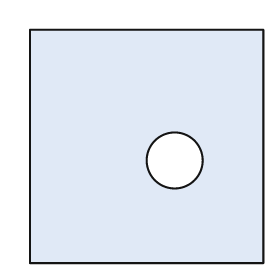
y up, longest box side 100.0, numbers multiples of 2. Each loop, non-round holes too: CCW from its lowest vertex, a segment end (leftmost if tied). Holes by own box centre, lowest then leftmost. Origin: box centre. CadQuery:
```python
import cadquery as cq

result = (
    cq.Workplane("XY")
    .moveTo(-50.0, -50.0)
    .lineTo(50.0, -50.0)
    .lineTo(50.0, 50.0)
    .lineTo(-50.0, 50.0)
    .close()
    .moveTo(12.0, -6.0)
    .circle(12.0)
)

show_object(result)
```